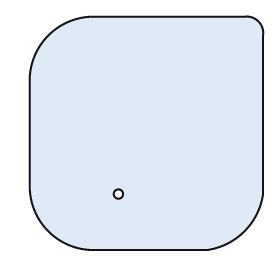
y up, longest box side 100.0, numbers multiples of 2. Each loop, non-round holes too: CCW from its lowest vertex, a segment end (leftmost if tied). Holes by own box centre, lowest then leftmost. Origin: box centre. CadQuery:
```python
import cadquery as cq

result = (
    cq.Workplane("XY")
    .moveTo(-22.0, -50.0)
    .lineTo(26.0, -50.0)
    .threePointArc((42.0, -42.0), (50.0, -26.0))
    .lineTo(50.0, 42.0)
    .threePointArc((48.0, 48.0), (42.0, 50.0))
    .lineTo(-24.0, 50.0)
    .threePointArc((-42.0, 42.0), (-50.0, 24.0))
    .lineTo(-50.0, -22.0)
    .threePointArc((-42.0, -42.0), (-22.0, -50.0))
    .close()
    .moveTo(-12.0, -26.0)
    .circle(2.0)
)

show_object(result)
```